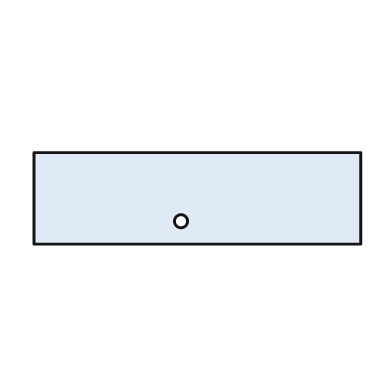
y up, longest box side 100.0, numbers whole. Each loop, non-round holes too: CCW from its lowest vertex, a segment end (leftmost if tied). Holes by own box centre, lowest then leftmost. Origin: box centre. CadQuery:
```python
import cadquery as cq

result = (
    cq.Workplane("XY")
    .moveTo(-50.0, -14.0)
    .lineTo(50.0, -14.0)
    .lineTo(50.0, 14.0)
    .lineTo(-50.0, 14.0)
    .close()
    .moveTo(-5.0, -7.0)
    .circle(2.0)
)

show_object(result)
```